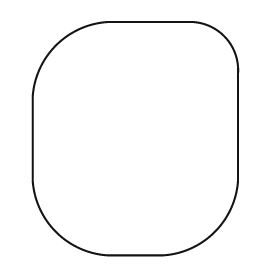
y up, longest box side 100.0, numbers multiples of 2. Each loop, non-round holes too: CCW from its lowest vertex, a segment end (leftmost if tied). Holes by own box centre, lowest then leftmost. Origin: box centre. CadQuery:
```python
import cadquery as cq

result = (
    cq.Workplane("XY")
    .moveTo(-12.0, -50.0)
    .lineTo(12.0, -50.0)
    .threePointArc((34.0, -40.0), (44.0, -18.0))
    .lineTo(44.0, 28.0)
    .threePointArc((38.0, 44.0), (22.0, 50.0))
    .lineTo(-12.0, 50.0)
    .threePointArc((-34.0, 40.0), (-44.0, 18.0))
    .lineTo(-44.0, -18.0)
    .threePointArc((-34.0, -40.0), (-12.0, -50.0))
    .close()
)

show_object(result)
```